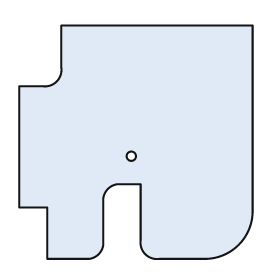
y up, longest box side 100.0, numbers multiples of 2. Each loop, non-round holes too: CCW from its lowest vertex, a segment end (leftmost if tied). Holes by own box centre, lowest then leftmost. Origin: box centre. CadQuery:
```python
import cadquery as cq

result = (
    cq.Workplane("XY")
    .moveTo(-38.0, -50.0)
    .lineTo(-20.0, -50.0)
    .threePointArc((-16.0, -48.0), (-14.0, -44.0))
    .lineTo(-14.0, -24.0)
    .threePointArc((-12.0, -20.0), (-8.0, -18.0))
    .lineTo(2.0, -18.0)
    .lineTo(2.0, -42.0)
    .threePointArc((4.0, -48.0), (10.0, -50.0))
    .lineTo(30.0, -50.0)
    .threePointArc((44.0, -44.0), (50.0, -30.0))
    .lineTo(50.0, 50.0)
    .lineTo(-32.0, 50.0)
    .lineTo(-32.0, 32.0)
    .threePointArc((-34.0, 26.0), (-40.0, 24.0))
    .lineTo(-50.0, 24.0)
    .lineTo(-50.0, -28.0)
    .lineTo(-38.0, -28.0)
    .close()
    .moveTo(-2.0, -6.0)
    .circle(2.0)
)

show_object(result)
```